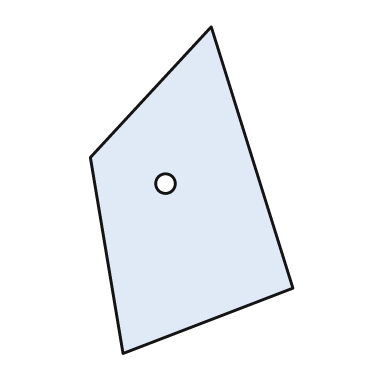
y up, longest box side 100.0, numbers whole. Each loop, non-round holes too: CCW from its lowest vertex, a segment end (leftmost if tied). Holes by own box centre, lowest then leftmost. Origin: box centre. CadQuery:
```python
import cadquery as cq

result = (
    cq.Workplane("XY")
    .moveTo(-21.0, -50.0)
    .lineTo(31.0, -30.0)
    .lineTo(6.0, 50.0)
    .lineTo(-31.0, 10.0)
    .close()
    .moveTo(-8.0, 2.0)
    .circle(3.0)
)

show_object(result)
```